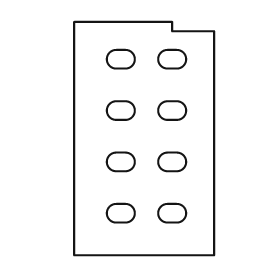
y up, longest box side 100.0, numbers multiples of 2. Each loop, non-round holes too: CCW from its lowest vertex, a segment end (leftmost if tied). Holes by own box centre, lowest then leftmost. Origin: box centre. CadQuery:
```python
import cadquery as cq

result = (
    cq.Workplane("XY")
    .moveTo(-30.0, -50.0)
    .lineTo(30.0, -50.0)
    .lineTo(30.0, 46.0)
    .lineTo(12.0, 46.0)
    .lineTo(12.0, 50.0)
    .lineTo(-30.0, 50.0)
    .close()
    .moveTo(-12.0, -36.0)
    .lineTo(-8.0, -36.0)
    .threePointArc((-4.0, -32.0), (-8.0, -28.0))
    .lineTo(-12.0, -28.0)
    .threePointArc((-16.0, -32.0), (-12.0, -36.0))
    .close()
    .moveTo(10.0, -36.0)
    .lineTo(14.0, -36.0)
    .threePointArc((18.0, -32.0), (14.0, -28.0))
    .lineTo(10.0, -28.0)
    .threePointArc((6.0, -32.0), (10.0, -36.0))
    .close()
    .moveTo(-12.0, -14.0)
    .lineTo(-8.0, -14.0)
    .threePointArc((-4.0, -10.0), (-8.0, -6.0))
    .lineTo(-12.0, -6.0)
    .threePointArc((-16.0, -10.0), (-12.0, -14.0))
    .close()
    .moveTo(10.0, -14.0)
    .lineTo(14.0, -14.0)
    .threePointArc((18.0, -10.0), (14.0, -6.0))
    .lineTo(10.0, -6.0)
    .threePointArc((6.0, -10.0), (10.0, -14.0))
    .close()
    .moveTo(-12.0, 8.0)
    .lineTo(-8.0, 8.0)
    .threePointArc((-4.0, 12.0), (-8.0, 16.0))
    .lineTo(-12.0, 16.0)
    .threePointArc((-16.0, 12.0), (-12.0, 8.0))
    .close()
    .moveTo(10.0, 8.0)
    .lineTo(14.0, 8.0)
    .threePointArc((18.0, 12.0), (14.0, 16.0))
    .lineTo(10.0, 16.0)
    .threePointArc((6.0, 12.0), (10.0, 8.0))
    .close()
    .moveTo(-12.0, 30.0)
    .lineTo(-8.0, 30.0)
    .threePointArc((-4.0, 34.0), (-8.0, 38.0))
    .lineTo(-12.0, 38.0)
    .threePointArc((-16.0, 34.0), (-12.0, 30.0))
    .close()
    .moveTo(10.0, 30.0)
    .lineTo(14.0, 30.0)
    .threePointArc((18.0, 34.0), (14.0, 38.0))
    .lineTo(10.0, 38.0)
    .threePointArc((6.0, 34.0), (10.0, 30.0))
    .close()
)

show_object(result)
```